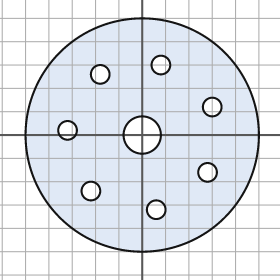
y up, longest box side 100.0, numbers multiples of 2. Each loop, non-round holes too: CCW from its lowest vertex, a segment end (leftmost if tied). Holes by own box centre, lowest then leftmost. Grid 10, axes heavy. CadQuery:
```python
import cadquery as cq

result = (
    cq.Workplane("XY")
    .moveTo(0.0, 0.0)
    .circle(50.0)
    .moveTo(6.0, -32.0)
    .circle(4.0)
    .moveTo(-22.0, -24.0)
    .circle(4.0)
    .moveTo(28.0, -16.0)
    .circle(4.0)
    .moveTo(0.0, 0.0)
    .circle(8.0)
    .moveTo(-32.0, 2.0)
    .circle(4.0)
    .moveTo(30.0, 12.0)
    .circle(4.0)
    .moveTo(-18.0, 26.0)
    .circle(4.0)
    .moveTo(8.0, 30.0)
    .circle(4.0)
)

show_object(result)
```